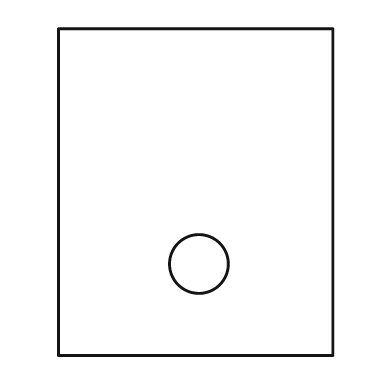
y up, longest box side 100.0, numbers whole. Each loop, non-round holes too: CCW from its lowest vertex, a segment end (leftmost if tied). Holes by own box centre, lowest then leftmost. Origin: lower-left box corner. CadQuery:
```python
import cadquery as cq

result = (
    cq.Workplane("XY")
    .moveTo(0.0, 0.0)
    .lineTo(84.0, 0.0)
    .lineTo(84.0, 100.0)
    .lineTo(0.0, 100.0)
    .close()
    .moveTo(43.0, 28.0)
    .circle(9.0)
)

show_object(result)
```